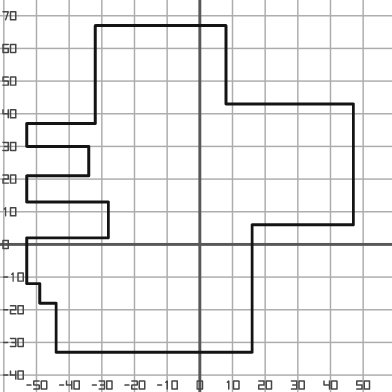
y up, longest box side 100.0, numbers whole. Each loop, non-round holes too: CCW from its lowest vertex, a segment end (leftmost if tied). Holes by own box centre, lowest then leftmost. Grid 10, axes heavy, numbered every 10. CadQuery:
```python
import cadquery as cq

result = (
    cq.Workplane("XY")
    .moveTo(-44.0, -33.0)
    .lineTo(16.0, -33.0)
    .lineTo(16.0, 6.0)
    .lineTo(47.0, 6.0)
    .lineTo(47.0, 43.0)
    .lineTo(8.0, 43.0)
    .lineTo(8.0, 67.0)
    .lineTo(-32.0, 67.0)
    .lineTo(-32.0, 37.0)
    .lineTo(-53.0, 37.0)
    .lineTo(-53.0, 30.0)
    .lineTo(-34.0, 30.0)
    .lineTo(-34.0, 21.0)
    .lineTo(-53.0, 21.0)
    .lineTo(-53.0, 13.0)
    .lineTo(-28.0, 13.0)
    .lineTo(-28.0, 2.0)
    .lineTo(-53.0, 2.0)
    .lineTo(-53.0, -12.0)
    .lineTo(-49.0, -12.0)
    .lineTo(-49.0, -18.0)
    .lineTo(-44.0, -18.0)
    .close()
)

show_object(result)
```